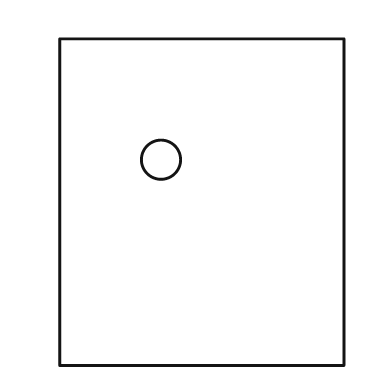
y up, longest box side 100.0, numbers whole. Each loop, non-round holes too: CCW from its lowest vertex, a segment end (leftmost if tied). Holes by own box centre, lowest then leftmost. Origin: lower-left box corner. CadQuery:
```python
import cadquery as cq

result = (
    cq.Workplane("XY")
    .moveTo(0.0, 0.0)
    .lineTo(87.0, 0.0)
    .lineTo(87.0, 100.0)
    .lineTo(0.0, 100.0)
    .close()
    .moveTo(31.0, 63.0)
    .circle(6.0)
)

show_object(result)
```